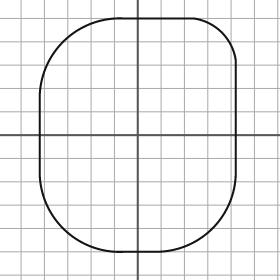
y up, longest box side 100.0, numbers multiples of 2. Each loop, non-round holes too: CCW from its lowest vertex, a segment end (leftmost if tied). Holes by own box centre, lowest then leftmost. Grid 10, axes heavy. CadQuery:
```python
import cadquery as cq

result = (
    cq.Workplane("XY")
    .moveTo(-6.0, -50.0)
    .lineTo(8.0, -50.0)
    .threePointArc((32.0, -40.0), (42.0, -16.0))
    .lineTo(42.0, 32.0)
    .threePointArc((36.0, 44.0), (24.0, 50.0))
    .lineTo(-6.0, 50.0)
    .threePointArc((-32.0, 40.0), (-42.0, 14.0))
    .lineTo(-42.0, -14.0)
    .threePointArc((-32.0, -40.0), (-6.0, -50.0))
    .close()
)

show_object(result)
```